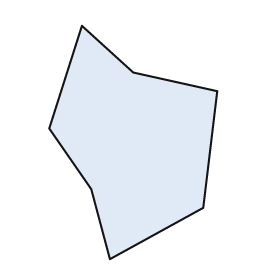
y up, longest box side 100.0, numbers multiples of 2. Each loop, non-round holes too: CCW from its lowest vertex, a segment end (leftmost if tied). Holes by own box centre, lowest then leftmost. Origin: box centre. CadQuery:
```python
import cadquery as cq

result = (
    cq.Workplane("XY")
    .moveTo(-10.0, -50.0)
    .lineTo(30.0, -28.0)
    .lineTo(36.0, 22.0)
    .lineTo(0.0, 30.0)
    .lineTo(-22.0, 50.0)
    .lineTo(-36.0, 6.0)
    .lineTo(-18.0, -20.0)
    .close()
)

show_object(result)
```